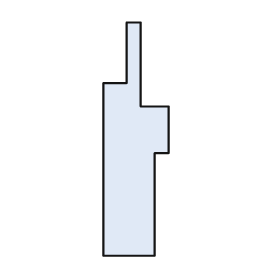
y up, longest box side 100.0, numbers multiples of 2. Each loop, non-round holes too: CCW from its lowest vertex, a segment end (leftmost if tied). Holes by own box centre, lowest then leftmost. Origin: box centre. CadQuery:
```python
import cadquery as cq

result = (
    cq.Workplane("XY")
    .moveTo(-14.0, -50.0)
    .lineTo(8.0, -50.0)
    .lineTo(8.0, -6.0)
    .lineTo(14.0, -6.0)
    .lineTo(14.0, 14.0)
    .lineTo(2.0, 14.0)
    .lineTo(2.0, 50.0)
    .lineTo(-4.0, 50.0)
    .lineTo(-4.0, 24.0)
    .lineTo(-14.0, 24.0)
    .close()
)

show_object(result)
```